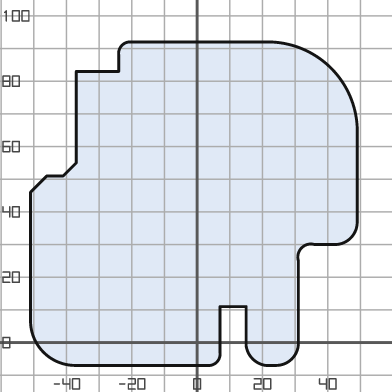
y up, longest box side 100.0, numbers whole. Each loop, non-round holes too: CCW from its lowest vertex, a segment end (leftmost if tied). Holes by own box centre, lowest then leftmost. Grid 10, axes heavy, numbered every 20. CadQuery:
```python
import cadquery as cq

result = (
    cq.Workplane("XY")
    .moveTo(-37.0, -7.0)
    .lineTo(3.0, -7.0)
    .threePointArc((6.0, -6.0), (7.0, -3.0))
    .lineTo(7.0, 11.0)
    .lineTo(15.0, 11.0)
    .lineTo(15.0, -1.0)
    .threePointArc((17.0, -5.0), (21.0, -7.0))
    .lineTo(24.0, -7.0)
    .threePointArc((29.0, -5.0), (31.0, 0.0))
    .lineTo(31.0, 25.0)
    .threePointArc((32.0, 29.0), (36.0, 30.0))
    .lineTo(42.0, 30.0)
    .threePointArc((47.0, 32.0), (49.0, 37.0))
    .lineTo(49.0, 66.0)
    .threePointArc((41.0, 84.0), (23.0, 92.0))
    .lineTo(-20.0, 92.0)
    .threePointArc((-23.0, 91.0), (-24.0, 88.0))
    .lineTo(-24.0, 83.0)
    .lineTo(-37.0, 83.0)
    .lineTo(-37.0, 55.0)
    .lineTo(-41.0, 51.0)
    .lineTo(-46.0, 51.0)
    .lineTo(-51.0, 46.0)
    .lineTo(-51.0, 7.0)
    .threePointArc((-47.0, -3.0), (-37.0, -7.0))
    .close()
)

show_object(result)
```